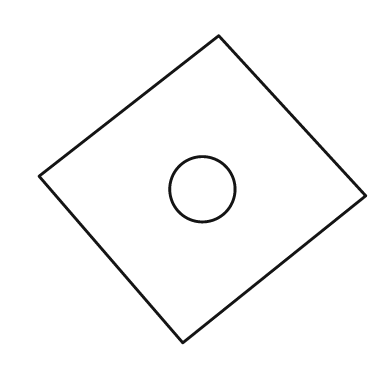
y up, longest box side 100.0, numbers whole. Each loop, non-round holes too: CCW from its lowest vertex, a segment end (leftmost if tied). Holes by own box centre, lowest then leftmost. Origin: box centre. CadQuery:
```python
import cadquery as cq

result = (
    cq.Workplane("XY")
    .moveTo(-6.0, -47.0)
    .lineTo(50.0, -2.0)
    .lineTo(5.0, 47.0)
    .lineTo(-50.0, 4.0)
    .close()
    .moveTo(0.0, 0.0)
    .circle(10.0)
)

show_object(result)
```